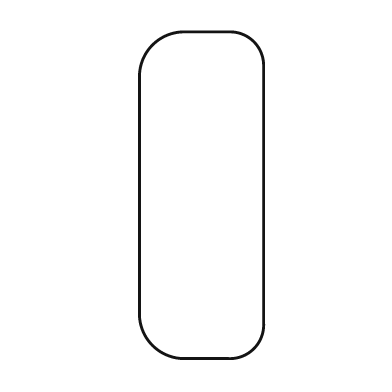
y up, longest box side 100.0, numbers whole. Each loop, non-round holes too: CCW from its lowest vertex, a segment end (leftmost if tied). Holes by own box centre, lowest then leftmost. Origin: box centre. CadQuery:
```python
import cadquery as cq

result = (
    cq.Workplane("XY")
    .moveTo(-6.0, -50.0)
    .lineTo(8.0, -50.0)
    .threePointArc((16.0, -47.0), (19.0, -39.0))
    .lineTo(19.0, 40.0)
    .threePointArc((16.0, 47.0), (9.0, 50.0))
    .lineTo(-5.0, 50.0)
    .threePointArc((-15.0, 46.0), (-19.0, 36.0))
    .lineTo(-19.0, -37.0)
    .threePointArc((-15.0, -46.0), (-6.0, -50.0))
    .close()
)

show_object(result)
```